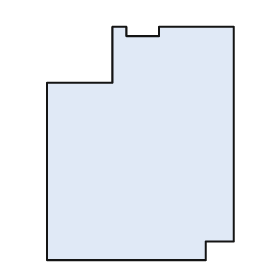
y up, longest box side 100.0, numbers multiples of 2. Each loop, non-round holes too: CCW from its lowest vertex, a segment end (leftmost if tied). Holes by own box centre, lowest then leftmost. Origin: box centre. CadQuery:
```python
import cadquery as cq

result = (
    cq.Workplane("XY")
    .moveTo(-40.0, -50.0)
    .lineTo(28.0, -50.0)
    .lineTo(28.0, -42.0)
    .lineTo(40.0, -42.0)
    .lineTo(40.0, 50.0)
    .lineTo(8.0, 50.0)
    .lineTo(8.0, 46.0)
    .lineTo(-6.0, 46.0)
    .lineTo(-6.0, 50.0)
    .lineTo(-12.0, 50.0)
    .lineTo(-12.0, 26.0)
    .lineTo(-40.0, 26.0)
    .close()
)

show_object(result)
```